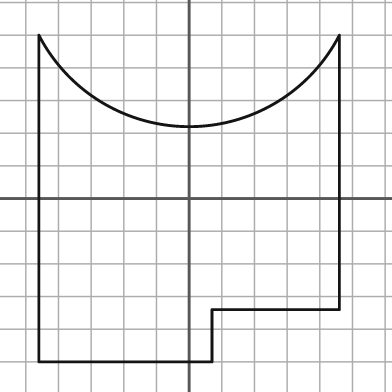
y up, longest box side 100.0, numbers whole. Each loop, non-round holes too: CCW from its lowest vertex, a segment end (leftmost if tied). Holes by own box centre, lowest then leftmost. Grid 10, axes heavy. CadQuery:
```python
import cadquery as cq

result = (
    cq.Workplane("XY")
    .moveTo(-46.0, -50.0)
    .lineTo(7.0, -50.0)
    .lineTo(7.0, -34.0)
    .lineTo(46.0, -34.0)
    .lineTo(46.0, 50.0)
    .threePointArc((0.0, 22.0), (-46.0, 50.0))
    .close()
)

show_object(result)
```